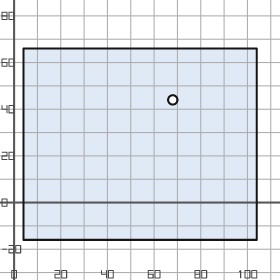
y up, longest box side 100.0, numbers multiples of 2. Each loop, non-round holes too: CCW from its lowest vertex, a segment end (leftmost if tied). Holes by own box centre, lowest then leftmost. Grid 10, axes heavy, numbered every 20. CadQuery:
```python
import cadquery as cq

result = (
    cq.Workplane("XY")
    .moveTo(4.0, -16.0)
    .lineTo(104.0, -16.0)
    .lineTo(104.0, 66.0)
    .lineTo(4.0, 66.0)
    .close()
    .moveTo(68.0, 44.0)
    .circle(2.0)
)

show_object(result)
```